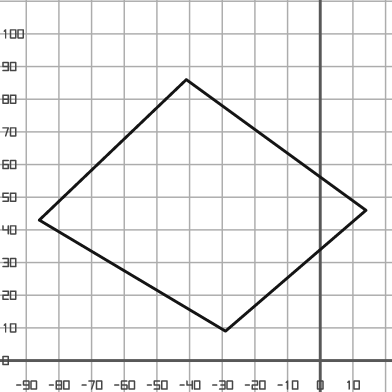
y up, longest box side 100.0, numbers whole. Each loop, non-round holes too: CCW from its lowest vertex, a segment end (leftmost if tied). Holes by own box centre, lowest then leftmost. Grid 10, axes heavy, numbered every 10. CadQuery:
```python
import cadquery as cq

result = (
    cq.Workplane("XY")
    .moveTo(-29.0, 9.0)
    .lineTo(14.0, 46.0)
    .lineTo(-41.0, 86.0)
    .lineTo(-86.0, 43.0)
    .close()
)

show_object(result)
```